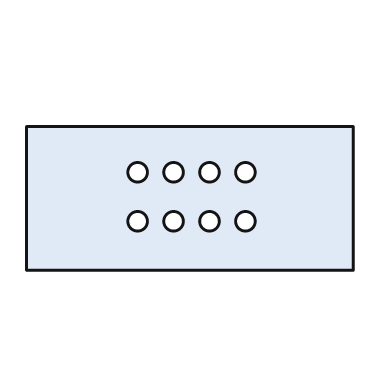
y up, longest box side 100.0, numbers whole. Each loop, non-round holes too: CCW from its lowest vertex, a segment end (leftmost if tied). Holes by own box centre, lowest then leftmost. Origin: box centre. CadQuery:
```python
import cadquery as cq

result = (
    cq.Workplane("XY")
    .moveTo(-50.0, -22.0)
    .lineTo(50.0, -22.0)
    .lineTo(50.0, 22.0)
    .lineTo(-50.0, 22.0)
    .close()
    .moveTo(-16.0, -7.0)
    .circle(3.0)
    .moveTo(-5.0, -7.0)
    .circle(3.0)
    .moveTo(6.0, -7.0)
    .circle(3.0)
    .moveTo(17.0, -7.0)
    .circle(3.0)
    .moveTo(-16.0, 8.0)
    .circle(3.0)
    .moveTo(-5.0, 8.0)
    .circle(3.0)
    .moveTo(6.0, 8.0)
    .circle(3.0)
    .moveTo(17.0, 8.0)
    .circle(3.0)
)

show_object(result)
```